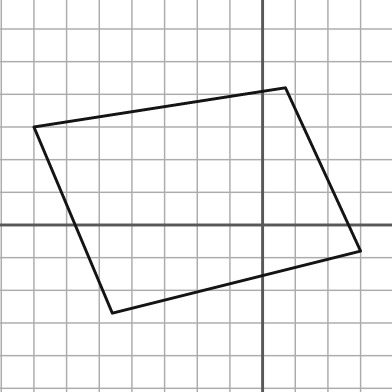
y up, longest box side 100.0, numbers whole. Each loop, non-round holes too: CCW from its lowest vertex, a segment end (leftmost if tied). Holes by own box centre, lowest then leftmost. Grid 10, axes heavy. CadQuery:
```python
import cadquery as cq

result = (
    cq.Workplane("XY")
    .moveTo(-46.0, -27.0)
    .lineTo(30.0, -8.0)
    .lineTo(7.0, 42.0)
    .lineTo(-70.0, 30.0)
    .close()
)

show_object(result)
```